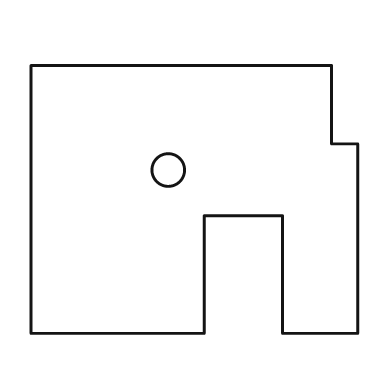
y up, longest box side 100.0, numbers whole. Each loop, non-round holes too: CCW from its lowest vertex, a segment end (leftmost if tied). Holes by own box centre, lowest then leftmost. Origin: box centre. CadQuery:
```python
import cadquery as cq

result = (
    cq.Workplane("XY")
    .moveTo(-50.0, -41.0)
    .lineTo(3.0, -41.0)
    .lineTo(3.0, -5.0)
    .lineTo(27.0, -5.0)
    .lineTo(27.0, -41.0)
    .lineTo(50.0, -41.0)
    .lineTo(50.0, 17.0)
    .lineTo(42.0, 17.0)
    .lineTo(42.0, 41.0)
    .lineTo(-50.0, 41.0)
    .close()
    .moveTo(-8.0, 9.0)
    .circle(5.0)
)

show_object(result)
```